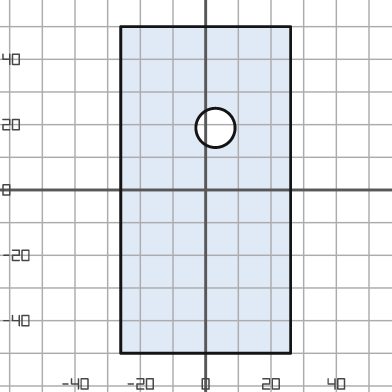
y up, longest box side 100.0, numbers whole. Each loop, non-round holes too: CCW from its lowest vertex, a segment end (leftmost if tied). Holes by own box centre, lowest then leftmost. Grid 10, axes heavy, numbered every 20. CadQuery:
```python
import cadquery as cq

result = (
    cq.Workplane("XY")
    .moveTo(-26.0, -50.0)
    .lineTo(26.0, -50.0)
    .lineTo(26.0, 50.0)
    .lineTo(-26.0, 50.0)
    .close()
    .moveTo(3.0, 19.0)
    .circle(6.0)
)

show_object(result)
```